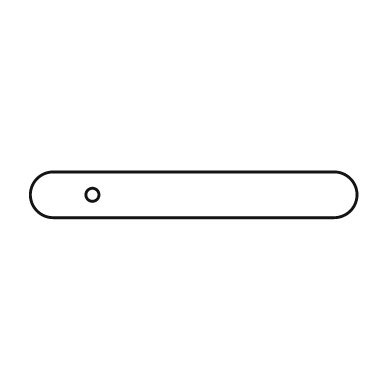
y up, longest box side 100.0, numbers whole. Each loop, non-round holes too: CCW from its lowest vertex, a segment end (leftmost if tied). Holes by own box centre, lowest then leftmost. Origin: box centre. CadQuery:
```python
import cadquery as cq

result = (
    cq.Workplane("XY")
    .moveTo(-43.0, -7.0)
    .lineTo(43.0, -7.0)
    .threePointArc((50.0, 0.0), (43.0, 7.0))
    .lineTo(-43.0, 7.0)
    .threePointArc((-50.0, 0.0), (-43.0, -7.0))
    .close()
    .moveTo(-31.0, 0.0)
    .circle(2.0)
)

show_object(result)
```